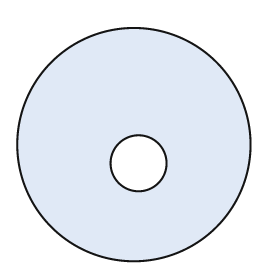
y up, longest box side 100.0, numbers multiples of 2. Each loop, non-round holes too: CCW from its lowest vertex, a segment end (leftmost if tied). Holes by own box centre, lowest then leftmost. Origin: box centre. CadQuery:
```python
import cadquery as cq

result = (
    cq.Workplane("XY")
    .moveTo(0.0, 0.0)
    .circle(50.0)
    .moveTo(2.0, -8.0)
    .circle(12.0)
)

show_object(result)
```